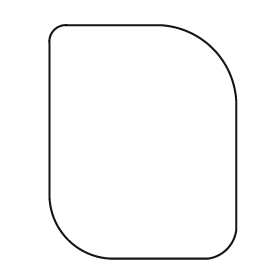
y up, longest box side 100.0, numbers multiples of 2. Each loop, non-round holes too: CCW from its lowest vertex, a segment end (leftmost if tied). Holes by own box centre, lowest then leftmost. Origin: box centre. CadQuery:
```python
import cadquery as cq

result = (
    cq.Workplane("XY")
    .moveTo(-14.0, -50.0)
    .lineTo(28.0, -50.0)
    .threePointArc((36.0, -46.0), (40.0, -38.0))
    .lineTo(40.0, 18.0)
    .threePointArc((30.0, 40.0), (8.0, 50.0))
    .lineTo(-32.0, 50.0)
    .threePointArc((-38.0, 48.0), (-40.0, 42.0))
    .lineTo(-40.0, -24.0)
    .threePointArc((-32.0, -42.0), (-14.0, -50.0))
    .close()
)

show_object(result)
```